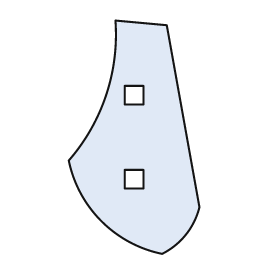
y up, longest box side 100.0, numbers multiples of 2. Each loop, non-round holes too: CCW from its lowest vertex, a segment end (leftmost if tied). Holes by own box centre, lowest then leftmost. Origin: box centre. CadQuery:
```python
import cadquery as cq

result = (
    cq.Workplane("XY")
    .moveTo(12.0, -50.0)
    .threePointArc((22.0, -42.0), (28.0, -30.0))
    .lineTo(14.0, 48.0)
    .lineTo(-8.0, 50.0)
    .threePointArc((-12.0, 18.0), (-28.0, -10.0))
    .threePointArc((-14.0, -36.0), (12.0, -50.0))
    .close()
    .moveTo(-4.0, -22.0)
    .lineTo(4.0, -22.0)
    .lineTo(4.0, -14.0)
    .lineTo(-4.0, -14.0)
    .close()
    .moveTo(-4.0, 14.0)
    .lineTo(4.0, 14.0)
    .lineTo(4.0, 22.0)
    .lineTo(-4.0, 22.0)
    .close()
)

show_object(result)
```